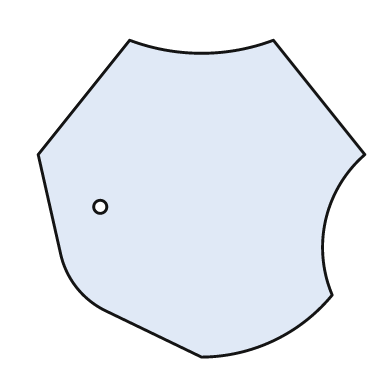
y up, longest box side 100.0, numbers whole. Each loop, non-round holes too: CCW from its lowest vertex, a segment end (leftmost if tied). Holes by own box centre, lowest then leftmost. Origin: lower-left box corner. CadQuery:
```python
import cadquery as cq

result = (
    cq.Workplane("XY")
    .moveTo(50.0, 0.0)
    .threePointArc((72.0, 5.0), (90.0, 19.0))
    .threePointArc((88.0, 42.0), (100.0, 62.0))
    .lineTo(72.0, 97.0)
    .threePointArc((50.0, 93.0), (28.0, 97.0))
    .lineTo(0.0, 62.0)
    .lineTo(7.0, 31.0)
    .threePointArc((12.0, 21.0), (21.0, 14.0))
    .close()
    .moveTo(19.0, 46.0)
    .circle(2.0)
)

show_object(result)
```